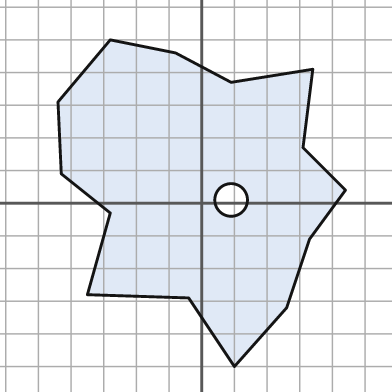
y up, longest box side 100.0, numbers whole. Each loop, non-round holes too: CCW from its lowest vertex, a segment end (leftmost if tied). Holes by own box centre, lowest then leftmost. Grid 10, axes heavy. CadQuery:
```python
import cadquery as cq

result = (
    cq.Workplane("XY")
    .moveTo(10.0, -50.0)
    .lineTo(26.0, -32.0)
    .lineTo(33.0, -11.0)
    .lineTo(44.0, 4.0)
    .lineTo(31.0, 17.0)
    .lineTo(34.0, 41.0)
    .lineTo(9.0, 37.0)
    .lineTo(-8.0, 46.0)
    .lineTo(-28.0, 50.0)
    .lineTo(-44.0, 31.0)
    .lineTo(-43.0, 9.0)
    .lineTo(-28.0, -3.0)
    .lineTo(-35.0, -28.0)
    .lineTo(-4.0, -29.0)
    .close()
    .moveTo(9.0, 1.0)
    .circle(5.0)
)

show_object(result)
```